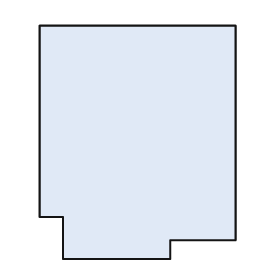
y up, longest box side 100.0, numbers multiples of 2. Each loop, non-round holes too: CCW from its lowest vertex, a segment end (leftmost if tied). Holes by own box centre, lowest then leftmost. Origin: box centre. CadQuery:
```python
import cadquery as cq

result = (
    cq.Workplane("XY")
    .moveTo(-32.0, -50.0)
    .lineTo(14.0, -50.0)
    .lineTo(14.0, -42.0)
    .lineTo(42.0, -42.0)
    .lineTo(42.0, 50.0)
    .lineTo(-42.0, 50.0)
    .lineTo(-42.0, -32.0)
    .lineTo(-32.0, -32.0)
    .close()
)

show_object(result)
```